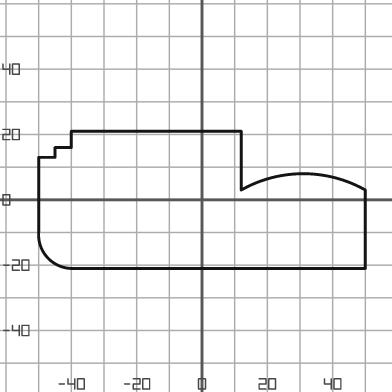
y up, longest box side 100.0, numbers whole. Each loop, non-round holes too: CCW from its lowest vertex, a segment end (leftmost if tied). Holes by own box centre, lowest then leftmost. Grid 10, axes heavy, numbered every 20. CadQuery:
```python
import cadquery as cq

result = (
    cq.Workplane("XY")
    .moveTo(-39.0, -21.0)
    .lineTo(50.0, -21.0)
    .lineTo(50.0, 3.0)
    .threePointArc((31.0, 8.0), (12.0, 3.0))
    .lineTo(12.0, 21.0)
    .lineTo(-40.0, 21.0)
    .lineTo(-40.0, 16.0)
    .lineTo(-45.0, 16.0)
    .lineTo(-45.0, 13.0)
    .lineTo(-50.0, 13.0)
    .lineTo(-50.0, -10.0)
    .threePointArc((-47.0, -18.0), (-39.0, -21.0))
    .close()
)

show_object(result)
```